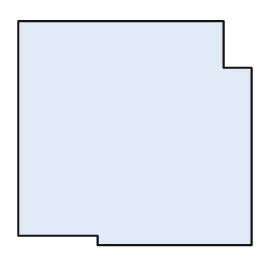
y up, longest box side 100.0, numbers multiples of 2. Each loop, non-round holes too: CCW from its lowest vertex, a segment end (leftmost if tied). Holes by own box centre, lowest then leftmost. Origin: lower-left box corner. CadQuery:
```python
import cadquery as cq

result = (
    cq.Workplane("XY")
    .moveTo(34.0, 0.0)
    .lineTo(100.0, 0.0)
    .lineTo(100.0, 76.0)
    .lineTo(88.0, 76.0)
    .lineTo(88.0, 96.0)
    .lineTo(0.0, 96.0)
    .lineTo(0.0, 4.0)
    .lineTo(34.0, 4.0)
    .close()
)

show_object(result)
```